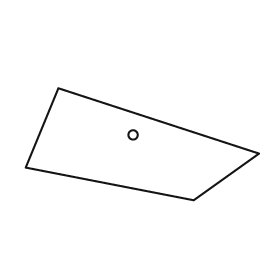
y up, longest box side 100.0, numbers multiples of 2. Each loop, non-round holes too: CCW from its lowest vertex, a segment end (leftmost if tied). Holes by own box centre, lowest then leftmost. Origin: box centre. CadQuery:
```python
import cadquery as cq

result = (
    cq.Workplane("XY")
    .moveTo(22.0, -24.0)
    .lineTo(50.0, -4.0)
    .lineTo(-36.0, 24.0)
    .lineTo(-50.0, -10.0)
    .close()
    .moveTo(-4.0, 4.0)
    .circle(2.0)
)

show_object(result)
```